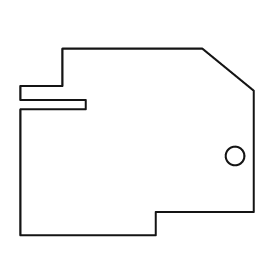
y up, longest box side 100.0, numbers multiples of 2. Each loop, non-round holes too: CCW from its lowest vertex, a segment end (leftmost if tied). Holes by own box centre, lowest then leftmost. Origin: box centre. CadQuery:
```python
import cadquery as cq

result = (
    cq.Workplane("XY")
    .moveTo(-50.0, -40.0)
    .lineTo(8.0, -40.0)
    .lineTo(8.0, -30.0)
    .lineTo(50.0, -30.0)
    .lineTo(50.0, 22.0)
    .lineTo(28.0, 40.0)
    .lineTo(-32.0, 40.0)
    .lineTo(-32.0, 24.0)
    .lineTo(-50.0, 24.0)
    .lineTo(-50.0, 18.0)
    .lineTo(-22.0, 18.0)
    .lineTo(-22.0, 14.0)
    .lineTo(-50.0, 14.0)
    .close()
    .moveTo(42.0, -6.0)
    .circle(4.0)
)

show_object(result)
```